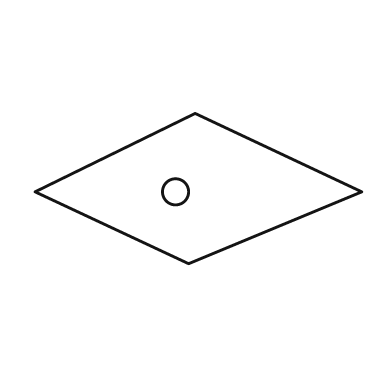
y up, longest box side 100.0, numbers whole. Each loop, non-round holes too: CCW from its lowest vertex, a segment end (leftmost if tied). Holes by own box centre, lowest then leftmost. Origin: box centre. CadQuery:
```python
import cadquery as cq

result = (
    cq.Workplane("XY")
    .moveTo(-3.0, -23.0)
    .lineTo(50.0, -1.0)
    .lineTo(-1.0, 23.0)
    .lineTo(-50.0, -1.0)
    .close()
    .moveTo(-7.0, -1.0)
    .circle(4.0)
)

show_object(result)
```